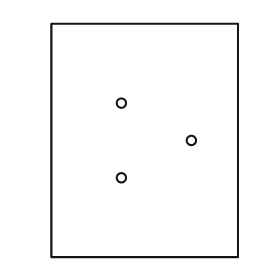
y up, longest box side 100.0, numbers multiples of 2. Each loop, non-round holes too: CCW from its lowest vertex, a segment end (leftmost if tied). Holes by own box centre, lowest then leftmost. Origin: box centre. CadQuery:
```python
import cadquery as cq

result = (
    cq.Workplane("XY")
    .moveTo(-40.0, -50.0)
    .lineTo(40.0, -50.0)
    .lineTo(40.0, 50.0)
    .lineTo(-40.0, 50.0)
    .close()
    .moveTo(-10.0, -16.0)
    .circle(2.0)
    .moveTo(20.0, 0.0)
    .circle(2.0)
    .moveTo(-10.0, 16.0)
    .circle(2.0)
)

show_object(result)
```